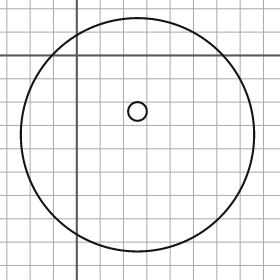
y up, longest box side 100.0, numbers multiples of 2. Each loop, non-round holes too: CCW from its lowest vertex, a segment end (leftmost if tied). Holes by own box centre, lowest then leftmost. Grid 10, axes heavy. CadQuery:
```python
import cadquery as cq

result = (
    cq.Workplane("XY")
    .moveTo(26.0, -34.0)
    .circle(50.0)
    .moveTo(26.0, -24.0)
    .circle(4.0)
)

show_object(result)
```